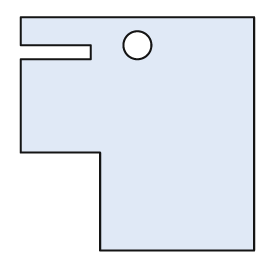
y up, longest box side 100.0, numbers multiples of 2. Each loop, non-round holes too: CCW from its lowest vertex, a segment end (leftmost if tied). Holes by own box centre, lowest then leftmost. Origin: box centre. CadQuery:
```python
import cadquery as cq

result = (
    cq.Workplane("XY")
    .moveTo(-16.0, -50.0)
    .lineTo(50.0, -50.0)
    .lineTo(50.0, 50.0)
    .lineTo(-50.0, 50.0)
    .lineTo(-50.0, 38.0)
    .lineTo(-20.0, 38.0)
    .lineTo(-20.0, 32.0)
    .lineTo(-50.0, 32.0)
    .lineTo(-50.0, -8.0)
    .lineTo(-16.0, -8.0)
    .close()
    .moveTo(0.0, 38.0)
    .circle(6.0)
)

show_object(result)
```